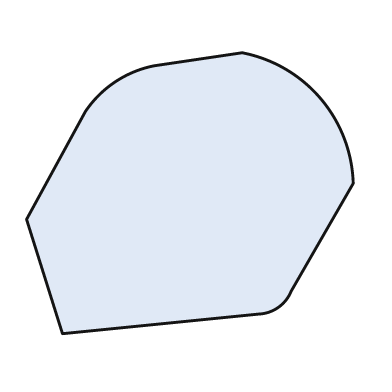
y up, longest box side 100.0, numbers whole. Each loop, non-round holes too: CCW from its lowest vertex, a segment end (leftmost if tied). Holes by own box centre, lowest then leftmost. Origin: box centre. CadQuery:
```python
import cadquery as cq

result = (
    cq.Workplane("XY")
    .moveTo(-39.0, -43.0)
    .lineTo(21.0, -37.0)
    .threePointArc((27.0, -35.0), (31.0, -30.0))
    .lineTo(50.0, 3.0)
    .threePointArc((40.0, 29.0), (16.0, 43.0))
    .lineTo(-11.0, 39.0)
    .threePointArc((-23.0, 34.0), (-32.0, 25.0))
    .lineTo(-50.0, -8.0)
    .close()
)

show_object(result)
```